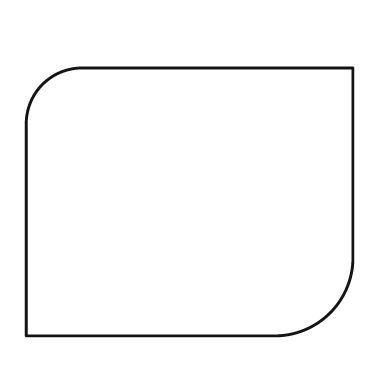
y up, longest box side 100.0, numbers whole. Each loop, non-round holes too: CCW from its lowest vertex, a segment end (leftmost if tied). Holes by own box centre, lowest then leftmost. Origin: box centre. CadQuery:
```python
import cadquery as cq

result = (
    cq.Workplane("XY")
    .moveTo(-50.0, -41.0)
    .lineTo(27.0, -41.0)
    .threePointArc((43.0, -34.0), (50.0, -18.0))
    .lineTo(50.0, 41.0)
    .lineTo(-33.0, 41.0)
    .threePointArc((-45.0, 36.0), (-50.0, 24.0))
    .close()
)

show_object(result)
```